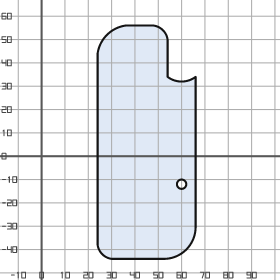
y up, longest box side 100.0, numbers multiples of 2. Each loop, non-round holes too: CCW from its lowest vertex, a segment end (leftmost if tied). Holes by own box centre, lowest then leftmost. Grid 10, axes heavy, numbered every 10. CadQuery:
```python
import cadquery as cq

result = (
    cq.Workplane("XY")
    .moveTo(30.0, -44.0)
    .lineTo(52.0, -44.0)
    .threePointArc((62.0, -40.0), (66.0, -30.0))
    .lineTo(66.0, 34.0)
    .threePointArc((60.0, 32.0), (54.0, 34.0))
    .lineTo(54.0, 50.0)
    .threePointArc((52.0, 54.0), (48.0, 56.0))
    .lineTo(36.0, 56.0)
    .threePointArc((28.0, 52.0), (24.0, 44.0))
    .lineTo(24.0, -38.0)
    .threePointArc((26.0, -42.0), (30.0, -44.0))
    .close()
    .moveTo(60.0, -12.0)
    .circle(2.0)
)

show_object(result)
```